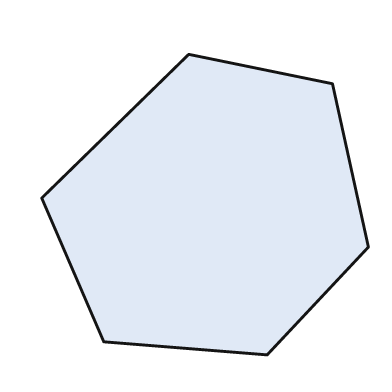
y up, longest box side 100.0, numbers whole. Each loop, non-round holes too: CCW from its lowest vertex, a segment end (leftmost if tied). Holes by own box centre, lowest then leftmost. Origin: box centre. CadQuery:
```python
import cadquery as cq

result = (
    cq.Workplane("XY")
    .moveTo(19.0, -46.0)
    .lineTo(50.0, -13.0)
    .lineTo(39.0, 37.0)
    .lineTo(-5.0, 46.0)
    .lineTo(-50.0, 2.0)
    .lineTo(-31.0, -42.0)
    .close()
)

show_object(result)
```